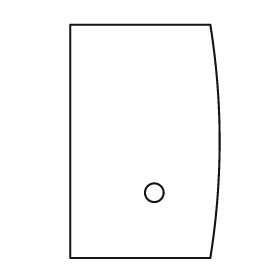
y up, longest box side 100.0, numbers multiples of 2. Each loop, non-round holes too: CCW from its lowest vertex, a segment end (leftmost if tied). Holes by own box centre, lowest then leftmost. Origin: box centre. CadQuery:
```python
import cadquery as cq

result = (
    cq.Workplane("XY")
    .moveTo(-32.0, -50.0)
    .lineTo(28.0, -50.0)
    .threePointArc((32.0, 0.0), (28.0, 50.0))
    .lineTo(-32.0, 50.0)
    .close()
    .moveTo(4.0, -22.0)
    .circle(4.0)
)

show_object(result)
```